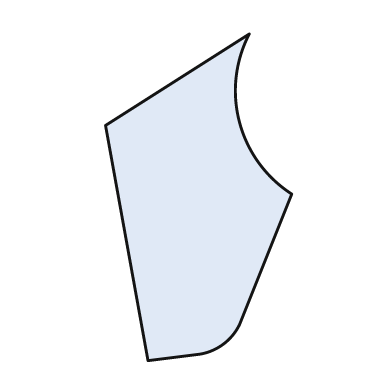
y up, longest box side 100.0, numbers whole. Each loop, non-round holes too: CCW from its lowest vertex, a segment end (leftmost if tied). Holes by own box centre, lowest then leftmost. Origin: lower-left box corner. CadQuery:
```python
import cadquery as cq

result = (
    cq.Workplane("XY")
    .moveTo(13.0, 0.0)
    .lineTo(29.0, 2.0)
    .threePointArc((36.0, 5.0), (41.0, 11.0))
    .lineTo(57.0, 51.0)
    .threePointArc((41.0, 73.0), (44.0, 100.0))
    .lineTo(0.0, 72.0)
    .close()
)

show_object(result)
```